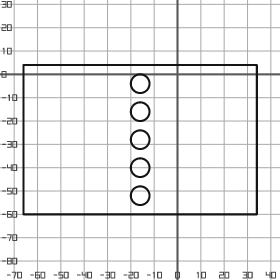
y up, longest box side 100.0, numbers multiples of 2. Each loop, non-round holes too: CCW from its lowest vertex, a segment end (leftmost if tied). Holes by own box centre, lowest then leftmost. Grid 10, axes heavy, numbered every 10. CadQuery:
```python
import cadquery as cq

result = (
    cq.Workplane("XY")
    .moveTo(-66.0, -60.0)
    .lineTo(34.0, -60.0)
    .lineTo(34.0, 4.0)
    .lineTo(-66.0, 4.0)
    .close()
    .moveTo(-16.0, -52.0)
    .circle(4.0)
    .moveTo(-16.0, -40.0)
    .circle(4.0)
    .moveTo(-16.0, -28.0)
    .circle(4.0)
    .moveTo(-16.0, -16.0)
    .circle(4.0)
    .moveTo(-16.0, -4.0)
    .circle(4.0)
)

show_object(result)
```